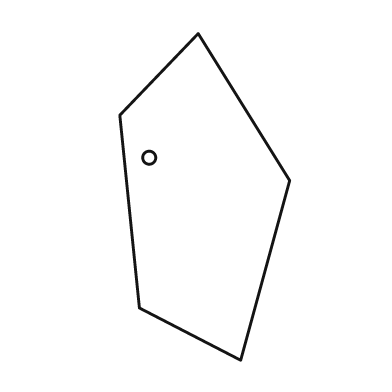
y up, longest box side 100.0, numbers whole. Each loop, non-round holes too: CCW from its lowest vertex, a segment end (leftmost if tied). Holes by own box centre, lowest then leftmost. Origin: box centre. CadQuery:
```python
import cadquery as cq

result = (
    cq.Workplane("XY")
    .moveTo(11.0, -50.0)
    .lineTo(26.0, 5.0)
    .lineTo(-2.0, 50.0)
    .lineTo(-26.0, 25.0)
    .lineTo(-20.0, -34.0)
    .close()
    .moveTo(-17.0, 12.0)
    .circle(2.0)
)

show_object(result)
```